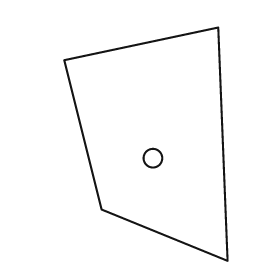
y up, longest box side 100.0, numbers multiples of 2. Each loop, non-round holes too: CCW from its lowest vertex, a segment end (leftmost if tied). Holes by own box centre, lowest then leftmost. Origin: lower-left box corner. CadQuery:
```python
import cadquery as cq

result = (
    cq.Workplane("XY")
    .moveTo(70.0, 0.0)
    .lineTo(66.0, 100.0)
    .lineTo(0.0, 86.0)
    .lineTo(16.0, 22.0)
    .close()
    .moveTo(38.0, 44.0)
    .circle(4.0)
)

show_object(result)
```